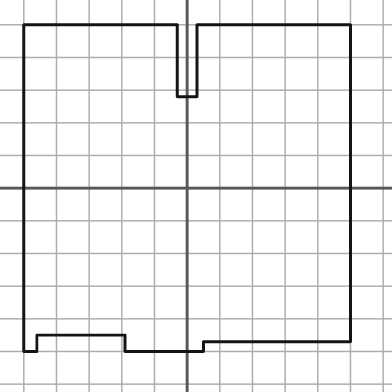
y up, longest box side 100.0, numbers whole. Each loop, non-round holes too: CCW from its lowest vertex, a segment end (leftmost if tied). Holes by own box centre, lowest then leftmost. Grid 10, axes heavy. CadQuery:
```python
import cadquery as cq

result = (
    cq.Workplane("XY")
    .moveTo(-50.0, -50.0)
    .lineTo(-46.0, -50.0)
    .lineTo(-46.0, -45.0)
    .lineTo(-19.0, -45.0)
    .lineTo(-19.0, -50.0)
    .lineTo(5.0, -50.0)
    .lineTo(5.0, -47.0)
    .lineTo(50.0, -47.0)
    .lineTo(50.0, 50.0)
    .lineTo(3.0, 50.0)
    .lineTo(3.0, 28.0)
    .lineTo(-3.0, 28.0)
    .lineTo(-3.0, 50.0)
    .lineTo(-50.0, 50.0)
    .close()
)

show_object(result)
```